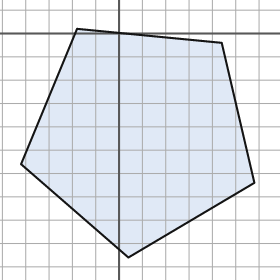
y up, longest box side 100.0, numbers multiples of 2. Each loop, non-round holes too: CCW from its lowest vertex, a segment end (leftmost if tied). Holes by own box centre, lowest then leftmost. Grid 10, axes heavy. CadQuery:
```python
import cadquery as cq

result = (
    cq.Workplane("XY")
    .moveTo(4.0, -96.0)
    .lineTo(58.0, -64.0)
    .lineTo(44.0, -4.0)
    .lineTo(-18.0, 2.0)
    .lineTo(-42.0, -56.0)
    .close()
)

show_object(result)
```